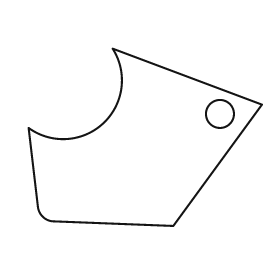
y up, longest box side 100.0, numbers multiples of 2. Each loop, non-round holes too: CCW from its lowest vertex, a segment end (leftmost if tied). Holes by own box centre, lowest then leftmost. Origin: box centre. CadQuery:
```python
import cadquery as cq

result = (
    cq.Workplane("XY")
    .moveTo(12.0, -38.0)
    .lineTo(50.0, 14.0)
    .lineTo(-14.0, 38.0)
    .threePointArc((-18.0, 6.0), (-50.0, 4.0))
    .lineTo(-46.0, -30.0)
    .threePointArc((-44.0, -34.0), (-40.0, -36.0))
    .close()
    .moveTo(32.0, 10.0)
    .circle(6.0)
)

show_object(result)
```